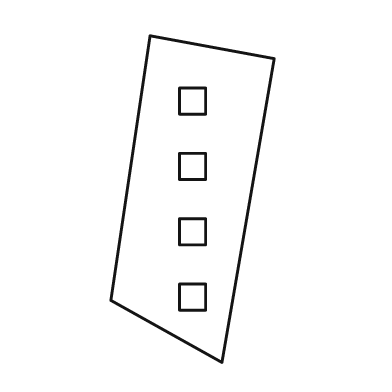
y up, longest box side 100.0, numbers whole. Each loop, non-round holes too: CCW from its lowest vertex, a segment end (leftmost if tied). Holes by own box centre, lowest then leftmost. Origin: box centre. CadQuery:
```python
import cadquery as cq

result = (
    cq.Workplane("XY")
    .moveTo(9.0, -50.0)
    .lineTo(25.0, 43.0)
    .lineTo(-13.0, 50.0)
    .lineTo(-25.0, -31.0)
    .close()
    .moveTo(-4.0, -34.0)
    .lineTo(4.0, -34.0)
    .lineTo(4.0, -26.0)
    .lineTo(-4.0, -26.0)
    .close()
    .moveTo(-4.0, -14.0)
    .lineTo(4.0, -14.0)
    .lineTo(4.0, -6.0)
    .lineTo(-4.0, -6.0)
    .close()
    .moveTo(-4.0, 6.0)
    .lineTo(4.0, 6.0)
    .lineTo(4.0, 14.0)
    .lineTo(-4.0, 14.0)
    .close()
    .moveTo(-4.0, 26.0)
    .lineTo(4.0, 26.0)
    .lineTo(4.0, 34.0)
    .lineTo(-4.0, 34.0)
    .close()
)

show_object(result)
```